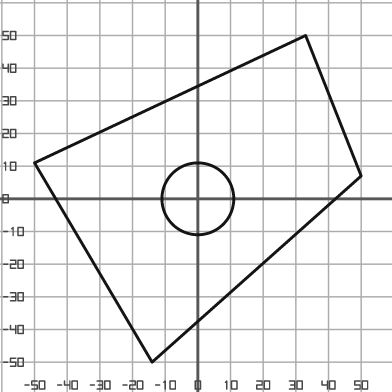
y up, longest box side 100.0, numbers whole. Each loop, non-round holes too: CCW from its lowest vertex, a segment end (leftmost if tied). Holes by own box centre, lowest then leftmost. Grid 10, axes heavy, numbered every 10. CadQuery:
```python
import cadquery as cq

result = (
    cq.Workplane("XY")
    .moveTo(-14.0, -50.0)
    .lineTo(50.0, 7.0)
    .lineTo(33.0, 50.0)
    .lineTo(-50.0, 11.0)
    .close()
    .moveTo(0.0, 0.0)
    .circle(11.0)
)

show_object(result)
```